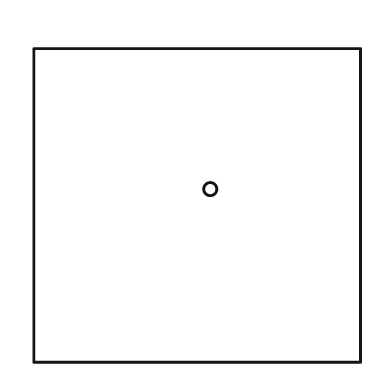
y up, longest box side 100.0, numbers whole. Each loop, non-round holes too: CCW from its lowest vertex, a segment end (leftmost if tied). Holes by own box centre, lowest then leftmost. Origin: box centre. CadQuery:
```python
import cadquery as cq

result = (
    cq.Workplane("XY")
    .moveTo(-50.0, -48.0)
    .lineTo(50.0, -48.0)
    .lineTo(50.0, 48.0)
    .lineTo(-50.0, 48.0)
    .close()
    .moveTo(4.0, 5.0)
    .circle(2.0)
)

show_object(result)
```